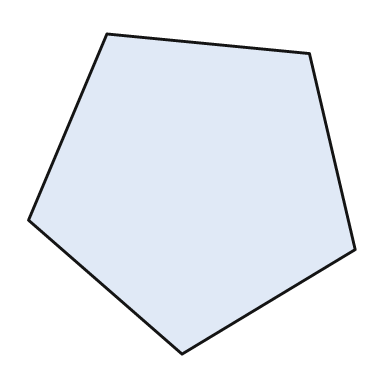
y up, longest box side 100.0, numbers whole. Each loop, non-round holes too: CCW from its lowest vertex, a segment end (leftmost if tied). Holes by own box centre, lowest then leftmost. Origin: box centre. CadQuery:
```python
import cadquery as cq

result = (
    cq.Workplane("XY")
    .moveTo(-3.0, -49.0)
    .lineTo(50.0, -17.0)
    .lineTo(36.0, 43.0)
    .lineTo(-26.0, 49.0)
    .lineTo(-50.0, -8.0)
    .close()
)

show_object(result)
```